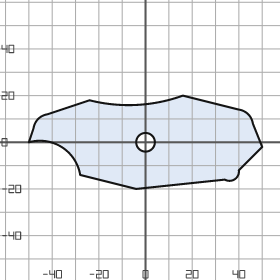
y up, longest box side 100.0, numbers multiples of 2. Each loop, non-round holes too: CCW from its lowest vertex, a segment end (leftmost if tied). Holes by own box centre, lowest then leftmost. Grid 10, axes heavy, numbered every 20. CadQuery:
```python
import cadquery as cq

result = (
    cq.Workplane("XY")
    .moveTo(-4.0, -20.0)
    .lineTo(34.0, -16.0)
    .threePointArc((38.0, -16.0), (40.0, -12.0))
    .lineTo(50.0, -2.0)
    .lineTo(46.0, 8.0)
    .threePointArc((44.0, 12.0), (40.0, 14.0))
    .lineTo(16.0, 20.0)
    .threePointArc((-4.0, 16.0), (-24.0, 18.0))
    .lineTo(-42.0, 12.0)
    .threePointArc((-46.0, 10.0), (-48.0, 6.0))
    .lineTo(-50.0, 0.0)
    .threePointArc((-36.0, -2.0), (-28.0, -14.0))
    .close()
    .moveTo(0.0, 0.0)
    .circle(4.0)
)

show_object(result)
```